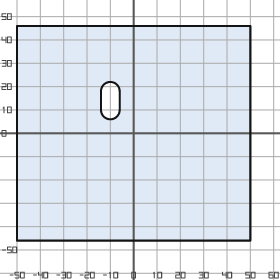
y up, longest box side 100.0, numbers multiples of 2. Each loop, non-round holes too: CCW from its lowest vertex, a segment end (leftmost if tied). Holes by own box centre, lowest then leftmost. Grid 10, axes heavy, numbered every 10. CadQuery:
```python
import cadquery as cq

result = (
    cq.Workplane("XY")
    .moveTo(-50.0, -46.0)
    .lineTo(50.0, -46.0)
    .lineTo(50.0, 46.0)
    .lineTo(-50.0, 46.0)
    .close()
    .moveTo(-14.0, 10.0)
    .threePointArc((-10.0, 6.0), (-6.0, 10.0))
    .lineTo(-6.0, 18.0)
    .threePointArc((-10.0, 22.0), (-14.0, 18.0))
    .close()
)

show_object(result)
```